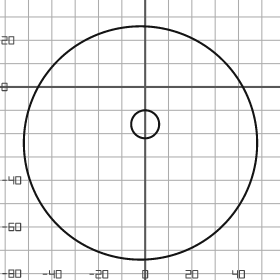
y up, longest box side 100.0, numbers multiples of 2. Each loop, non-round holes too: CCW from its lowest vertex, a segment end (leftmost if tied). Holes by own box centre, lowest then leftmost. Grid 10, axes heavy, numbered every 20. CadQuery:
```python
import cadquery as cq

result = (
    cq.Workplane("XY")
    .moveTo(-2.0, -24.0)
    .circle(50.0)
    .moveTo(0.0, -16.0)
    .circle(6.0)
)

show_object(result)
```